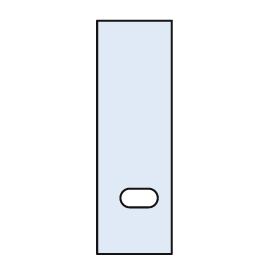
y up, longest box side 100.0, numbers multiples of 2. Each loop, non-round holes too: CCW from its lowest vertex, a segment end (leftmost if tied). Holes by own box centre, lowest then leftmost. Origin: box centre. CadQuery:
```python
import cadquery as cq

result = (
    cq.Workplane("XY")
    .moveTo(-16.0, -50.0)
    .lineTo(16.0, -50.0)
    .lineTo(16.0, 50.0)
    .lineTo(-16.0, 50.0)
    .close()
    .moveTo(-2.0, -30.0)
    .lineTo(6.0, -30.0)
    .threePointArc((10.0, -26.0), (6.0, -22.0))
    .lineTo(-2.0, -22.0)
    .threePointArc((-6.0, -26.0), (-2.0, -30.0))
    .close()
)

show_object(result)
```